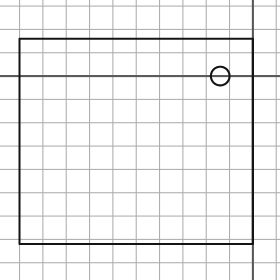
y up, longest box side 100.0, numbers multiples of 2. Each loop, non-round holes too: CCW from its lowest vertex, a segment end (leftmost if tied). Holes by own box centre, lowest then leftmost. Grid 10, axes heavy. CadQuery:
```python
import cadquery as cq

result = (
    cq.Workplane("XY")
    .moveTo(-100.0, -72.0)
    .lineTo(0.0, -72.0)
    .lineTo(0.0, 16.0)
    .lineTo(-100.0, 16.0)
    .close()
    .moveTo(-14.0, 0.0)
    .circle(4.0)
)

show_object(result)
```